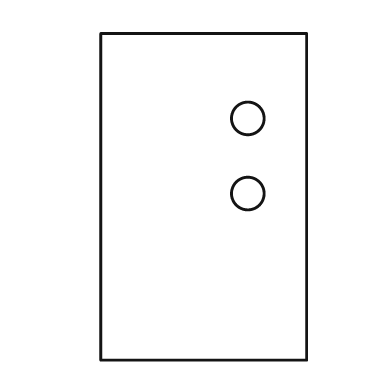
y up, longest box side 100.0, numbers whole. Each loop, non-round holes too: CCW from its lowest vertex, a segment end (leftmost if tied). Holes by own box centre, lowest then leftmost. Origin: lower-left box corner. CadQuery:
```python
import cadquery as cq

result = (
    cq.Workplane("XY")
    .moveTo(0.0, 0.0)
    .lineTo(63.0, 0.0)
    .lineTo(63.0, 100.0)
    .lineTo(0.0, 100.0)
    .close()
    .moveTo(45.0, 51.0)
    .circle(5.0)
    .moveTo(45.0, 74.0)
    .circle(5.0)
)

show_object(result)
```